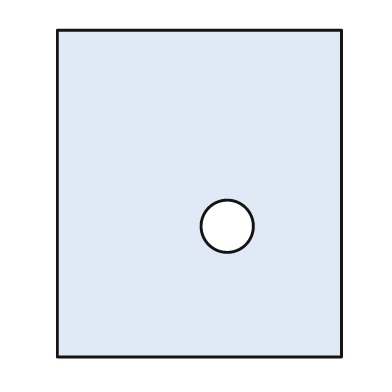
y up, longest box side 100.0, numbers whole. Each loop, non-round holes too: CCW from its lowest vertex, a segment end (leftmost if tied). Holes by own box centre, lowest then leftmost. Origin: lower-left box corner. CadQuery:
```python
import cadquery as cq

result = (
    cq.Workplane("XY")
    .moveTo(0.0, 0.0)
    .lineTo(87.0, 0.0)
    .lineTo(87.0, 100.0)
    .lineTo(0.0, 100.0)
    .close()
    .moveTo(52.0, 40.0)
    .circle(8.0)
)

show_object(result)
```